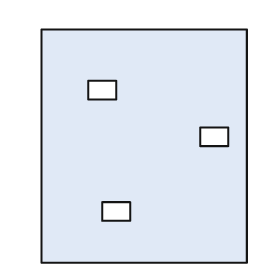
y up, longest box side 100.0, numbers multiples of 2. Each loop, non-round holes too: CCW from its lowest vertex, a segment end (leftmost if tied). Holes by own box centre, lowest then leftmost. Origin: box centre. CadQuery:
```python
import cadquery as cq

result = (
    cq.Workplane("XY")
    .moveTo(-44.0, -50.0)
    .lineTo(44.0, -50.0)
    .lineTo(44.0, 50.0)
    .lineTo(-44.0, 50.0)
    .close()
    .moveTo(-18.0, -32.0)
    .lineTo(-6.0, -32.0)
    .lineTo(-6.0, -24.0)
    .lineTo(-18.0, -24.0)
    .close()
    .moveTo(24.0, 0.0)
    .lineTo(36.0, 0.0)
    .lineTo(36.0, 8.0)
    .lineTo(24.0, 8.0)
    .close()
    .moveTo(-24.0, 20.0)
    .lineTo(-12.0, 20.0)
    .lineTo(-12.0, 28.0)
    .lineTo(-24.0, 28.0)
    .close()
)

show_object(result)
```